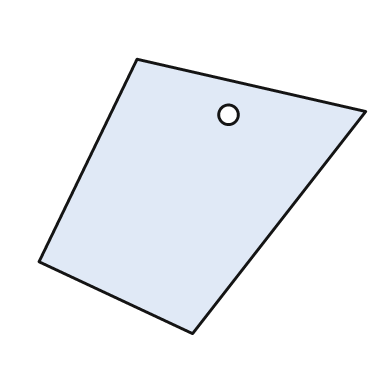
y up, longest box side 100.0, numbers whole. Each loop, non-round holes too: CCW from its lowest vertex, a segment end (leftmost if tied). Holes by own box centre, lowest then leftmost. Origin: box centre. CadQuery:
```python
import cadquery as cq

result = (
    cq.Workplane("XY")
    .moveTo(-3.0, -42.0)
    .lineTo(50.0, 26.0)
    .lineTo(-20.0, 42.0)
    .lineTo(-50.0, -20.0)
    .close()
    .moveTo(8.0, 25.0)
    .circle(3.0)
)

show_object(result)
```